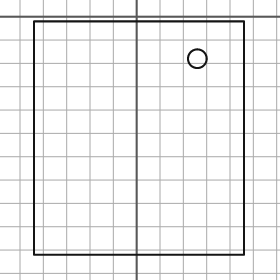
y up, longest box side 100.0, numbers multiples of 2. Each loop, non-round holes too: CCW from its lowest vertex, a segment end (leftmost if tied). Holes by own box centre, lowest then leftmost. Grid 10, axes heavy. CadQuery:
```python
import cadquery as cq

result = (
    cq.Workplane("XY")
    .moveTo(-44.0, -102.0)
    .lineTo(46.0, -102.0)
    .lineTo(46.0, -2.0)
    .lineTo(-44.0, -2.0)
    .close()
    .moveTo(26.0, -18.0)
    .circle(4.0)
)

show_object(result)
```